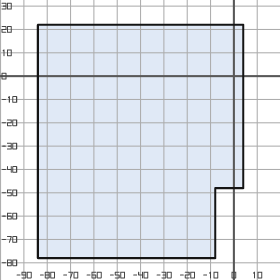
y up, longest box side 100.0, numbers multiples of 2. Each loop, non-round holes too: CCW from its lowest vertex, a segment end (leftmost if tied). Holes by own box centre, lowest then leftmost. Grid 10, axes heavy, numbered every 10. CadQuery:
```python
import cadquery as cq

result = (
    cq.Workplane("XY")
    .moveTo(-84.0, -78.0)
    .lineTo(-8.0, -78.0)
    .lineTo(-8.0, -48.0)
    .lineTo(4.0, -48.0)
    .lineTo(4.0, 22.0)
    .lineTo(-84.0, 22.0)
    .close()
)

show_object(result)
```